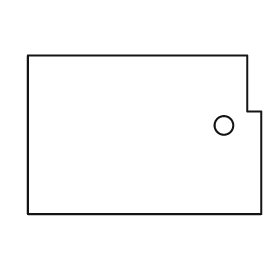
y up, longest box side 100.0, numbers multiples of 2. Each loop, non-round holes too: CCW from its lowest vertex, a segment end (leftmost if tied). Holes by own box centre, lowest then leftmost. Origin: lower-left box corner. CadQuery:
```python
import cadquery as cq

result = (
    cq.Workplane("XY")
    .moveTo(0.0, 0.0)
    .lineTo(100.0, 0.0)
    .lineTo(100.0, 44.0)
    .lineTo(94.0, 44.0)
    .lineTo(94.0, 68.0)
    .lineTo(0.0, 68.0)
    .close()
    .moveTo(84.0, 38.0)
    .circle(4.0)
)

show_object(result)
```